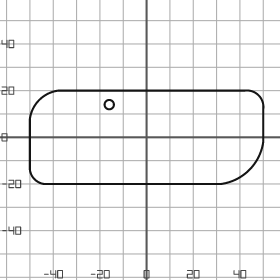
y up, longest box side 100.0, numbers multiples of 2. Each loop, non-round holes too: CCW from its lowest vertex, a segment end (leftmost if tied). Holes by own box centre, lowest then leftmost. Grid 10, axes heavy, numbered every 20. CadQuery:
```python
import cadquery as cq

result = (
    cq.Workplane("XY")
    .moveTo(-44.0, -20.0)
    .lineTo(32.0, -20.0)
    .threePointArc((44.0, -14.0), (50.0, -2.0))
    .lineTo(50.0, 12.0)
    .threePointArc((48.0, 18.0), (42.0, 20.0))
    .lineTo(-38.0, 20.0)
    .threePointArc((-46.0, 16.0), (-50.0, 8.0))
    .lineTo(-50.0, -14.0)
    .threePointArc((-48.0, -18.0), (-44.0, -20.0))
    .close()
    .moveTo(-16.0, 14.0)
    .circle(2.0)
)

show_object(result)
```